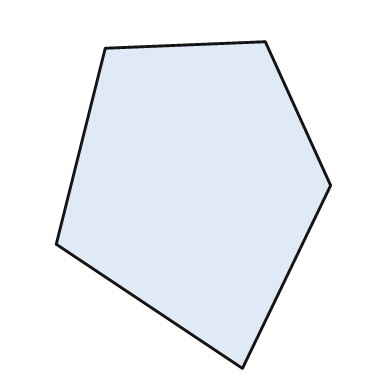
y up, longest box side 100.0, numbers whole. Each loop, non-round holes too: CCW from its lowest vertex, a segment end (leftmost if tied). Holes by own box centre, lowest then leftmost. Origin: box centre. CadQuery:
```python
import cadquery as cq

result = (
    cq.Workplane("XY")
    .moveTo(15.0, -50.0)
    .lineTo(42.0, 6.0)
    .lineTo(22.0, 50.0)
    .lineTo(-27.0, 48.0)
    .lineTo(-42.0, -12.0)
    .close()
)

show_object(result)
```